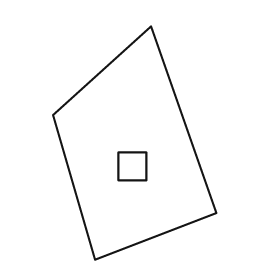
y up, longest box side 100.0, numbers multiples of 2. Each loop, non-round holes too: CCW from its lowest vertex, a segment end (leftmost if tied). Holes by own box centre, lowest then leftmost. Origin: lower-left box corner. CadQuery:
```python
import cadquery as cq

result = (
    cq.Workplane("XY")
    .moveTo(18.0, 0.0)
    .lineTo(70.0, 20.0)
    .lineTo(42.0, 100.0)
    .lineTo(0.0, 62.0)
    .close()
    .moveTo(28.0, 34.0)
    .lineTo(40.0, 34.0)
    .lineTo(40.0, 46.0)
    .lineTo(28.0, 46.0)
    .close()
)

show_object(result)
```